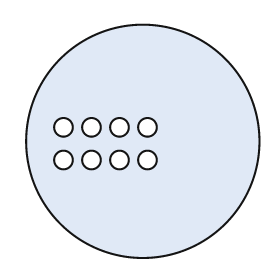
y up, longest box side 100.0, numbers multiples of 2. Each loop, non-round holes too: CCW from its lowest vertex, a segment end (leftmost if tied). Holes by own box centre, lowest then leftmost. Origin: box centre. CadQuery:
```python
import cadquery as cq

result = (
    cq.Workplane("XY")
    .moveTo(0.0, 0.0)
    .circle(50.0)
    .moveTo(-34.0, -8.0)
    .circle(4.0)
    .moveTo(-22.0, -8.0)
    .circle(4.0)
    .moveTo(-10.0, -8.0)
    .circle(4.0)
    .moveTo(2.0, -8.0)
    .circle(4.0)
    .moveTo(-34.0, 6.0)
    .circle(4.0)
    .moveTo(-22.0, 6.0)
    .circle(4.0)
    .moveTo(-10.0, 6.0)
    .circle(4.0)
    .moveTo(2.0, 6.0)
    .circle(4.0)
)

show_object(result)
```